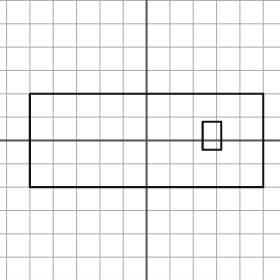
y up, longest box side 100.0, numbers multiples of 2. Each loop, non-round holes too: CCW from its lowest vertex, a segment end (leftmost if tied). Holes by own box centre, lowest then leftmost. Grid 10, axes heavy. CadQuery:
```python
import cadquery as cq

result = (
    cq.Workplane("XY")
    .moveTo(-50.0, -20.0)
    .lineTo(50.0, -20.0)
    .lineTo(50.0, 20.0)
    .lineTo(-50.0, 20.0)
    .close()
    .moveTo(24.0, -4.0)
    .lineTo(32.0, -4.0)
    .lineTo(32.0, 8.0)
    .lineTo(24.0, 8.0)
    .close()
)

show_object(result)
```